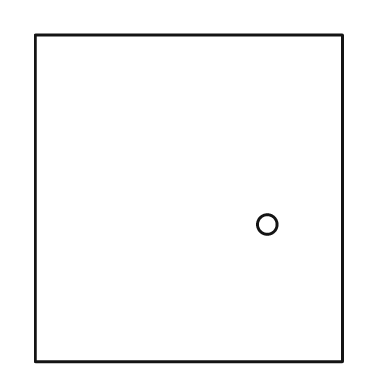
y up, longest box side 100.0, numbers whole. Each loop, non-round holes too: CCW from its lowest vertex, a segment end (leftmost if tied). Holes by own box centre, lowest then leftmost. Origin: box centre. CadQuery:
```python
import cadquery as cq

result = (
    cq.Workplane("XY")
    .moveTo(-47.0, -50.0)
    .lineTo(47.0, -50.0)
    .lineTo(47.0, 50.0)
    .lineTo(-47.0, 50.0)
    .close()
    .moveTo(24.0, -8.0)
    .circle(3.0)
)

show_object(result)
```